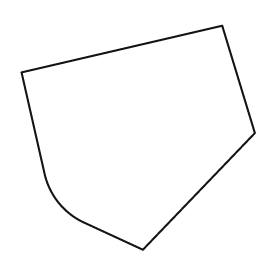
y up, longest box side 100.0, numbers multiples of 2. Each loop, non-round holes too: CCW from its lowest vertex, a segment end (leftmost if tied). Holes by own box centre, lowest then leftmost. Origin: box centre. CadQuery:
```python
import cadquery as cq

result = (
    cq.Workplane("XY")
    .moveTo(2.0, -48.0)
    .lineTo(50.0, 2.0)
    .lineTo(36.0, 48.0)
    .lineTo(-50.0, 28.0)
    .lineTo(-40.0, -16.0)
    .threePointArc((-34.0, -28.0), (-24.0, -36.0))
    .close()
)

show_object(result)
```